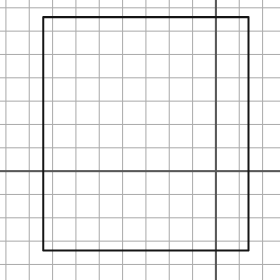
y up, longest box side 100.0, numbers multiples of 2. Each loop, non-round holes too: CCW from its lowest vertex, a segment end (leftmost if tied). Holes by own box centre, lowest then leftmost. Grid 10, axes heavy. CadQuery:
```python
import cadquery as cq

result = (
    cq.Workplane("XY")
    .moveTo(-74.0, -34.0)
    .lineTo(14.0, -34.0)
    .lineTo(14.0, 66.0)
    .lineTo(-74.0, 66.0)
    .close()
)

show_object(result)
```